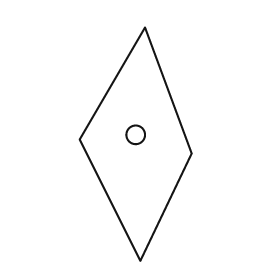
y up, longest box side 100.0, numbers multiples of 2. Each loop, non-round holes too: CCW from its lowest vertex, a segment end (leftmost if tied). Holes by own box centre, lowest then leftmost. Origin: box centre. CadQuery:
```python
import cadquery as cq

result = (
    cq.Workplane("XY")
    .moveTo(2.0, -50.0)
    .lineTo(24.0, -4.0)
    .lineTo(4.0, 50.0)
    .lineTo(-24.0, 2.0)
    .close()
    .moveTo(0.0, 4.0)
    .circle(4.0)
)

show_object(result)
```